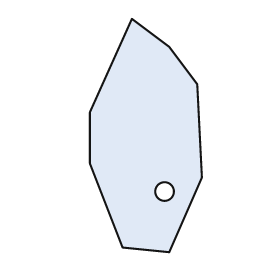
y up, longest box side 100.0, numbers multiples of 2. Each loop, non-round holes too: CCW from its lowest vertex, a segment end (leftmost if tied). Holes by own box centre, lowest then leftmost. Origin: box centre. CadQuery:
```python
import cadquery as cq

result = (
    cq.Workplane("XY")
    .moveTo(10.0, -50.0)
    .lineTo(24.0, -18.0)
    .lineTo(22.0, 22.0)
    .lineTo(10.0, 38.0)
    .lineTo(-6.0, 50.0)
    .lineTo(-24.0, 10.0)
    .lineTo(-24.0, -12.0)
    .lineTo(-10.0, -48.0)
    .close()
    .moveTo(8.0, -24.0)
    .circle(4.0)
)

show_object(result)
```